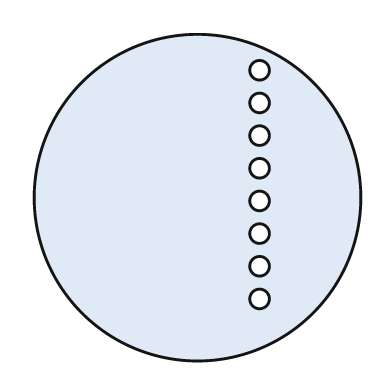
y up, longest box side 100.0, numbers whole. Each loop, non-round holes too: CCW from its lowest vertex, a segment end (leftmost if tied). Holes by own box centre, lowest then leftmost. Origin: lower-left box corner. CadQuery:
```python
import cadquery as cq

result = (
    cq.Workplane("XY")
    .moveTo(50.0, 50.0)
    .circle(50.0)
    .moveTo(69.0, 19.0)
    .circle(3.0)
    .moveTo(69.0, 29.0)
    .circle(3.0)
    .moveTo(69.0, 39.0)
    .circle(3.0)
    .moveTo(69.0, 49.0)
    .circle(3.0)
    .moveTo(69.0, 59.0)
    .circle(3.0)
    .moveTo(69.0, 69.0)
    .circle(3.0)
    .moveTo(69.0, 79.0)
    .circle(3.0)
    .moveTo(69.0, 89.0)
    .circle(3.0)
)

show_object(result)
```